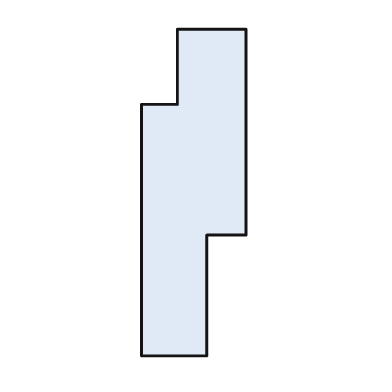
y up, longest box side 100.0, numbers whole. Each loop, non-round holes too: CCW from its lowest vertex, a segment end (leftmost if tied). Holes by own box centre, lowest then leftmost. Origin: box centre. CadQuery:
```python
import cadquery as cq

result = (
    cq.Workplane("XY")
    .moveTo(-16.0, -50.0)
    .lineTo(4.0, -50.0)
    .lineTo(4.0, -13.0)
    .lineTo(16.0, -13.0)
    .lineTo(16.0, 50.0)
    .lineTo(-5.0, 50.0)
    .lineTo(-5.0, 27.0)
    .lineTo(-16.0, 27.0)
    .close()
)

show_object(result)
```